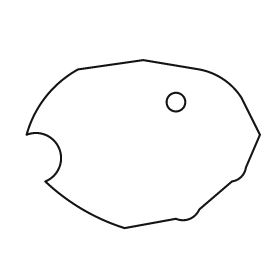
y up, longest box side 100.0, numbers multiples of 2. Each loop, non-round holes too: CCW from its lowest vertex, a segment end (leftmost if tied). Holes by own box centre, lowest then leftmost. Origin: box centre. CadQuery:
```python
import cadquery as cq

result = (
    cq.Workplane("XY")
    .moveTo(-8.0, -36.0)
    .lineTo(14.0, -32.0)
    .threePointArc((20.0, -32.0), (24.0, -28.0))
    .lineTo(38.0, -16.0)
    .threePointArc((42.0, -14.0), (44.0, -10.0))
    .lineTo(50.0, 4.0)
    .lineTo(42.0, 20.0)
    .threePointArc((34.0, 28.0), (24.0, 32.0))
    .lineTo(0.0, 36.0)
    .lineTo(-28.0, 32.0)
    .threePointArc((-42.0, 20.0), (-50.0, 4.0))
    .threePointArc((-36.0, -2.0), (-42.0, -16.0))
    .threePointArc((-26.0, -28.0), (-8.0, -36.0))
    .close()
    .moveTo(14.0, 18.0)
    .circle(4.0)
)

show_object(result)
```